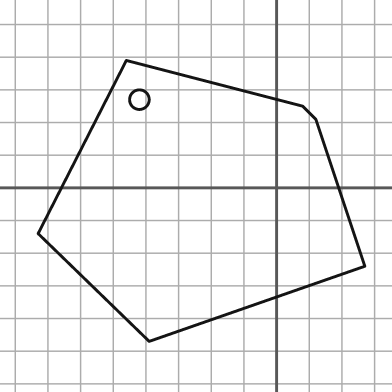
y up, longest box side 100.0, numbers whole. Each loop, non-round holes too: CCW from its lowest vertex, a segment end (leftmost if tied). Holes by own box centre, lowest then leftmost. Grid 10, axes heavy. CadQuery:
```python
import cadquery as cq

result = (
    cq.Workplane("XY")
    .moveTo(-39.0, -47.0)
    .lineTo(27.0, -24.0)
    .lineTo(12.0, 21.0)
    .lineTo(8.0, 25.0)
    .lineTo(-46.0, 39.0)
    .lineTo(-73.0, -14.0)
    .close()
    .moveTo(-42.0, 27.0)
    .circle(3.0)
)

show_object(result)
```